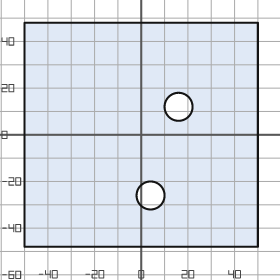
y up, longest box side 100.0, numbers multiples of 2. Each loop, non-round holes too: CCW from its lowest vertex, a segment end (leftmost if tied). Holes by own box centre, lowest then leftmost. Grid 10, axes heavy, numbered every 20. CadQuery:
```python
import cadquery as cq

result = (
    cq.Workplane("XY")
    .moveTo(-50.0, -48.0)
    .lineTo(50.0, -48.0)
    .lineTo(50.0, 48.0)
    .lineTo(-50.0, 48.0)
    .close()
    .moveTo(4.0, -26.0)
    .circle(6.0)
    .moveTo(16.0, 12.0)
    .circle(6.0)
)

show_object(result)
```